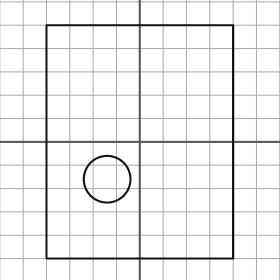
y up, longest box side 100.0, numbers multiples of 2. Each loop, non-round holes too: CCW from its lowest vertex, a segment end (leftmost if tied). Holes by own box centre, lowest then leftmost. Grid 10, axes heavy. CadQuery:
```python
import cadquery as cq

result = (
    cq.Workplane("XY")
    .moveTo(-40.0, -50.0)
    .lineTo(40.0, -50.0)
    .lineTo(40.0, 50.0)
    .lineTo(-40.0, 50.0)
    .close()
    .moveTo(-14.0, -16.0)
    .circle(10.0)
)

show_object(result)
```